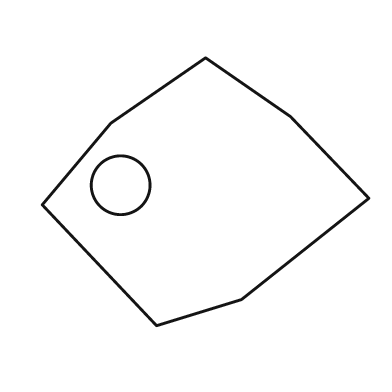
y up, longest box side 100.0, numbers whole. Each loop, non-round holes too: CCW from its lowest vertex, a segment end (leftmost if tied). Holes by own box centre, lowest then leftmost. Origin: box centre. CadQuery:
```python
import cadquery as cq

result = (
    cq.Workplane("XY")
    .moveTo(-15.0, -41.0)
    .lineTo(11.0, -33.0)
    .lineTo(50.0, -2.0)
    .lineTo(26.0, 23.0)
    .lineTo(0.0, 41.0)
    .lineTo(-29.0, 21.0)
    .lineTo(-50.0, -4.0)
    .close()
    .moveTo(-26.0, 2.0)
    .circle(9.0)
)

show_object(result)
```